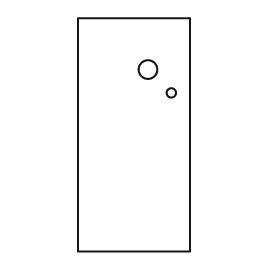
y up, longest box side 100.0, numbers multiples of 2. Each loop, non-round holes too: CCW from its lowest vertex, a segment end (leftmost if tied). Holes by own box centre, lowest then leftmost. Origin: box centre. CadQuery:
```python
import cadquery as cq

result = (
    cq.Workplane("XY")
    .moveTo(-24.0, -50.0)
    .lineTo(24.0, -50.0)
    .lineTo(24.0, 50.0)
    .lineTo(-24.0, 50.0)
    .close()
    .moveTo(16.0, 18.0)
    .circle(2.0)
    .moveTo(6.0, 28.0)
    .circle(4.0)
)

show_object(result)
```